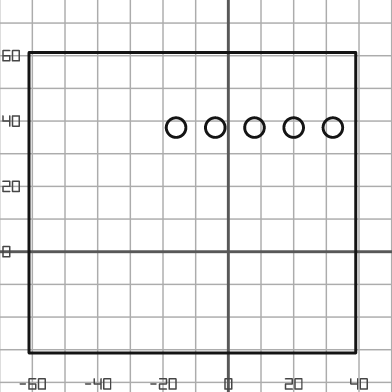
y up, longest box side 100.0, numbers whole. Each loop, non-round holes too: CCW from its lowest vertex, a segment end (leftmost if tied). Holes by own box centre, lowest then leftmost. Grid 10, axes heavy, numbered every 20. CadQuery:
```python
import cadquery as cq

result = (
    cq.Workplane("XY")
    .moveTo(-61.0, -31.0)
    .lineTo(39.0, -31.0)
    .lineTo(39.0, 61.0)
    .lineTo(-61.0, 61.0)
    .close()
    .moveTo(-16.0, 38.0)
    .circle(3.0)
    .moveTo(-4.0, 38.0)
    .circle(3.0)
    .moveTo(8.0, 38.0)
    .circle(3.0)
    .moveTo(20.0, 38.0)
    .circle(3.0)
    .moveTo(32.0, 38.0)
    .circle(3.0)
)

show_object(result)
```